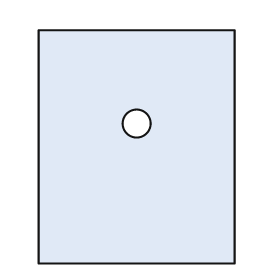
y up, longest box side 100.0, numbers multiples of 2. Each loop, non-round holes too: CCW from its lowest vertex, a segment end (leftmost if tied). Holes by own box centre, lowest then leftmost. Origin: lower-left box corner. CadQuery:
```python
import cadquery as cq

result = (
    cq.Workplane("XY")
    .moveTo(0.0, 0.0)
    .lineTo(84.0, 0.0)
    .lineTo(84.0, 100.0)
    .lineTo(0.0, 100.0)
    .close()
    .moveTo(42.0, 60.0)
    .circle(6.0)
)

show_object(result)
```